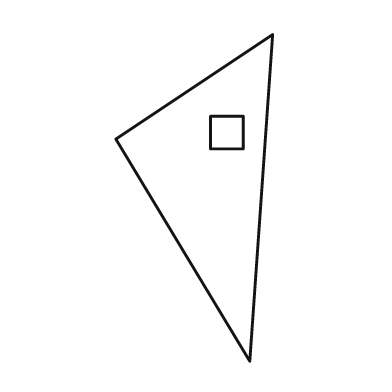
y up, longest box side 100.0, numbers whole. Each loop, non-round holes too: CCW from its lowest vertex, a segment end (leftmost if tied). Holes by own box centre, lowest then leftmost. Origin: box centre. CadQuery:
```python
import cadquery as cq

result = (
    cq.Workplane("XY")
    .moveTo(17.0, -50.0)
    .lineTo(24.0, 50.0)
    .lineTo(-24.0, 18.0)
    .close()
    .moveTo(5.0, 15.0)
    .lineTo(15.0, 15.0)
    .lineTo(15.0, 25.0)
    .lineTo(5.0, 25.0)
    .close()
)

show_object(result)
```